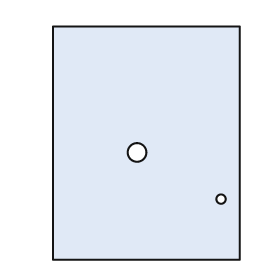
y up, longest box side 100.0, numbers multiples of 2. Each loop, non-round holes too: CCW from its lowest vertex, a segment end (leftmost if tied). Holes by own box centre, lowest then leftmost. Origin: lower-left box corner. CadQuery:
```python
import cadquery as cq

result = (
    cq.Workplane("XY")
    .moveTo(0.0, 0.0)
    .lineTo(80.0, 0.0)
    .lineTo(80.0, 100.0)
    .lineTo(0.0, 100.0)
    .close()
    .moveTo(72.0, 26.0)
    .circle(2.0)
    .moveTo(36.0, 46.0)
    .circle(4.0)
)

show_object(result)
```